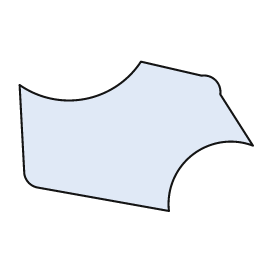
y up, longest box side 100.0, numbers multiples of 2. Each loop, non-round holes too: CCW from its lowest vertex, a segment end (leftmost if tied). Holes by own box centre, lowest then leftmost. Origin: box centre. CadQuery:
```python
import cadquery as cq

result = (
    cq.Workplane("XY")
    .moveTo(14.0, -32.0)
    .threePointArc((24.0, -8.0), (50.0, -4.0))
    .lineTo(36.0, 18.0)
    .threePointArc((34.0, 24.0), (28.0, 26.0))
    .lineTo(2.0, 32.0)
    .threePointArc((-22.0, 16.0), (-50.0, 22.0))
    .lineTo(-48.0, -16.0)
    .threePointArc((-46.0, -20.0), (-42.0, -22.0))
    .close()
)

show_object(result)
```